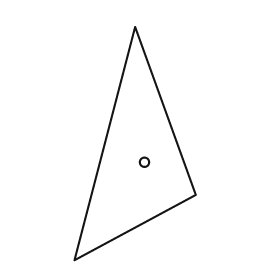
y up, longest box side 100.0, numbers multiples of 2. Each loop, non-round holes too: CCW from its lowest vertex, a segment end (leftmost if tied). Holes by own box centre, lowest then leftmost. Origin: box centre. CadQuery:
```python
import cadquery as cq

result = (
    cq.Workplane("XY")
    .moveTo(-26.0, -50.0)
    .lineTo(26.0, -22.0)
    .lineTo(0.0, 50.0)
    .close()
    .moveTo(4.0, -8.0)
    .circle(2.0)
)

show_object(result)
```